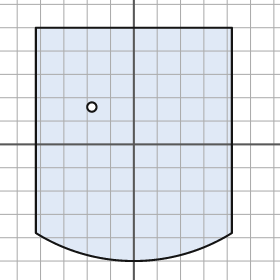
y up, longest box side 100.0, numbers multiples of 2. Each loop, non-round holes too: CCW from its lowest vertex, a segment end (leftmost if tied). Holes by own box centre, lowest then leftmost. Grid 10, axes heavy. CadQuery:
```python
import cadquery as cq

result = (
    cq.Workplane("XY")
    .moveTo(-42.0, -38.0)
    .threePointArc((0.0, -50.0), (42.0, -38.0))
    .lineTo(42.0, 50.0)
    .lineTo(-42.0, 50.0)
    .close()
    .moveTo(-18.0, 16.0)
    .circle(2.0)
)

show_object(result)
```